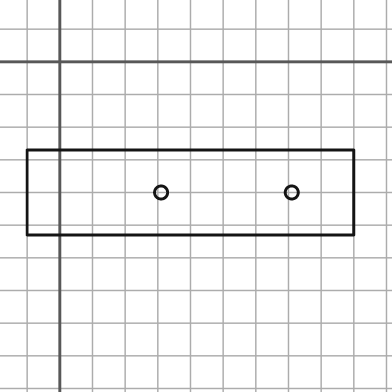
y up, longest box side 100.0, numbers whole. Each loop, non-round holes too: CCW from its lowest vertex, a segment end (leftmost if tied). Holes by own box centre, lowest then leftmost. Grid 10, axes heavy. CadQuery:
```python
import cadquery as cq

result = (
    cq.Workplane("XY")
    .moveTo(-10.0, -53.0)
    .lineTo(90.0, -53.0)
    .lineTo(90.0, -27.0)
    .lineTo(-10.0, -27.0)
    .close()
    .moveTo(31.0, -40.0)
    .circle(2.0)
    .moveTo(71.0, -40.0)
    .circle(2.0)
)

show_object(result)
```